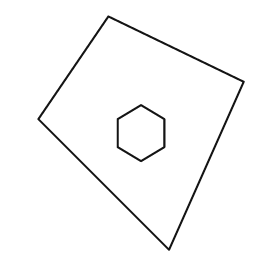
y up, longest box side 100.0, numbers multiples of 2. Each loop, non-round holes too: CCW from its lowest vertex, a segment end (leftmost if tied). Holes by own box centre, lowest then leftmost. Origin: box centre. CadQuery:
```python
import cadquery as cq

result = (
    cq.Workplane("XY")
    .moveTo(12.0, -50.0)
    .lineTo(44.0, 22.0)
    .lineTo(-14.0, 50.0)
    .lineTo(-44.0, 6.0)
    .close()
    .moveTo(0.0, -12.0)
    .lineTo(10.0, -6.0)
    .lineTo(10.0, 6.0)
    .lineTo(0.0, 12.0)
    .lineTo(-10.0, 6.0)
    .lineTo(-10.0, -6.0)
    .close()
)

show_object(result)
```